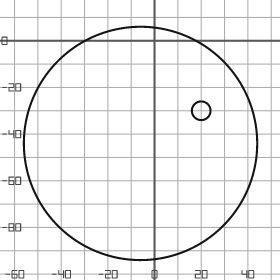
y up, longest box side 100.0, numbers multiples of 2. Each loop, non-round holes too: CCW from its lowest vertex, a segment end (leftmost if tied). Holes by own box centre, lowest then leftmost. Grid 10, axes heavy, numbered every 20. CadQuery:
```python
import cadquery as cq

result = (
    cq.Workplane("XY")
    .moveTo(-6.0, -44.0)
    .circle(50.0)
    .moveTo(20.0, -30.0)
    .circle(4.0)
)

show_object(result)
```